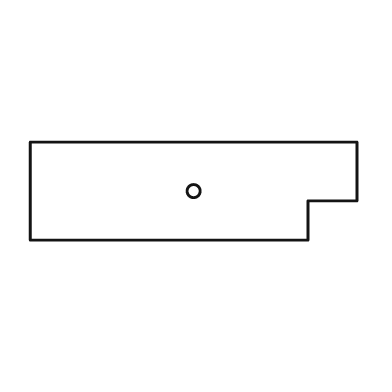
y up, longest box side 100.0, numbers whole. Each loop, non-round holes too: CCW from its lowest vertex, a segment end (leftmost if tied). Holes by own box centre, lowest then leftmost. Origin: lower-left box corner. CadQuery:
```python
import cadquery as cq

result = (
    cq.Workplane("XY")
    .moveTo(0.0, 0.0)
    .lineTo(85.0, 0.0)
    .lineTo(85.0, 12.0)
    .lineTo(100.0, 12.0)
    .lineTo(100.0, 30.0)
    .lineTo(0.0, 30.0)
    .close()
    .moveTo(50.0, 15.0)
    .circle(2.0)
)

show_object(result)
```